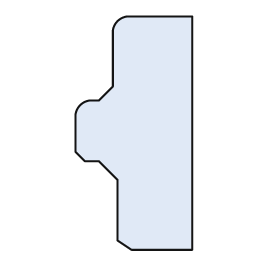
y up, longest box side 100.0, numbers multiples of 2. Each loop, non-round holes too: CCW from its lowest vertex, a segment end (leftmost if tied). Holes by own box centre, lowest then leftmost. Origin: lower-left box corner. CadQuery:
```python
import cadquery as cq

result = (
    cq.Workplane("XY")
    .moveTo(24.0, 0.0)
    .lineTo(50.0, 0.0)
    .lineTo(50.0, 100.0)
    .lineTo(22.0, 100.0)
    .threePointArc((18.0, 98.0), (16.0, 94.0))
    .lineTo(16.0, 70.0)
    .lineTo(10.0, 64.0)
    .lineTo(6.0, 64.0)
    .threePointArc((2.0, 62.0), (0.0, 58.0))
    .lineTo(0.0, 42.0)
    .lineTo(4.0, 38.0)
    .lineTo(10.0, 38.0)
    .lineTo(18.0, 30.0)
    .lineTo(18.0, 4.0)
    .close()
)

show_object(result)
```